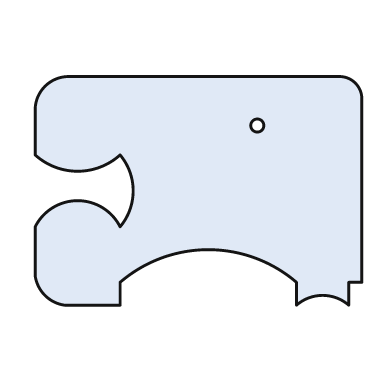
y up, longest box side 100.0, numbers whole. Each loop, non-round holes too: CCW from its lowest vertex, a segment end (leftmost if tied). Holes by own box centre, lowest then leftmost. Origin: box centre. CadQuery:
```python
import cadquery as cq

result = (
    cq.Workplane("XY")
    .moveTo(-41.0, -35.0)
    .lineTo(-24.0, -35.0)
    .lineTo(-24.0, -28.0)
    .threePointArc((3.0, -18.0), (30.0, -28.0))
    .lineTo(30.0, -35.0)
    .threePointArc((38.0, -32.0), (46.0, -35.0))
    .lineTo(46.0, -28.0)
    .lineTo(50.0, -28.0)
    .lineTo(50.0, 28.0)
    .threePointArc((48.0, 33.0), (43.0, 35.0))
    .lineTo(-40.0, 35.0)
    .threePointArc((-47.0, 32.0), (-50.0, 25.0))
    .lineTo(-50.0, 11.0)
    .threePointArc((-37.0, 6.0), (-24.0, 11.0))
    .threePointArc((-20.0, 0.0), (-24.0, -11.0))
    .threePointArc((-37.0, -3.0), (-50.0, -11.0))
    .lineTo(-50.0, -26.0)
    .threePointArc((-47.0, -32.0), (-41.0, -35.0))
    .close()
    .moveTo(18.0, 20.0)
    .circle(2.0)
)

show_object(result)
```